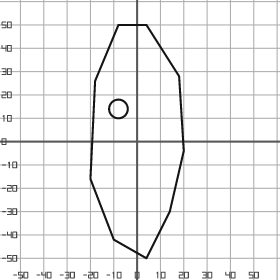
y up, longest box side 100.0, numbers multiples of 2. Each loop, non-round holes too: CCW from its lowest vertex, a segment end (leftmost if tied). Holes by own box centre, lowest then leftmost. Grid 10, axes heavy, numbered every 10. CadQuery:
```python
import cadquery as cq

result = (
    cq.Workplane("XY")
    .moveTo(4.0, -50.0)
    .lineTo(14.0, -30.0)
    .lineTo(20.0, -4.0)
    .lineTo(18.0, 28.0)
    .lineTo(4.0, 50.0)
    .lineTo(-8.0, 50.0)
    .lineTo(-18.0, 26.0)
    .lineTo(-20.0, -16.0)
    .lineTo(-10.0, -42.0)
    .close()
    .moveTo(-8.0, 14.0)
    .circle(4.0)
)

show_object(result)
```